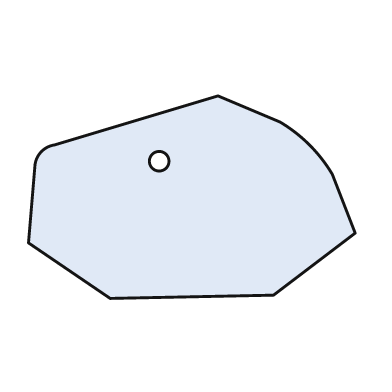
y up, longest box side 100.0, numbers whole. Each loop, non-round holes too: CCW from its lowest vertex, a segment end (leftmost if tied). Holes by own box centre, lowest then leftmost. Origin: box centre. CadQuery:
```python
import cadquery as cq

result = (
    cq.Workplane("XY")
    .moveTo(-25.0, -31.0)
    .lineTo(25.0, -30.0)
    .lineTo(50.0, -11.0)
    .lineTo(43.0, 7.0)
    .threePointArc((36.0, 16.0), (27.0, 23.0))
    .lineTo(8.0, 31.0)
    .lineTo(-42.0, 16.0)
    .threePointArc((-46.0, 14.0), (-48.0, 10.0))
    .lineTo(-50.0, -14.0)
    .close()
    .moveTo(-10.0, 11.0)
    .circle(3.0)
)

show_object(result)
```